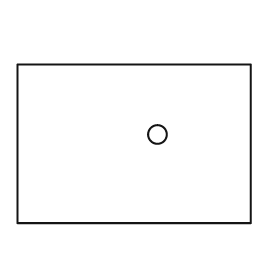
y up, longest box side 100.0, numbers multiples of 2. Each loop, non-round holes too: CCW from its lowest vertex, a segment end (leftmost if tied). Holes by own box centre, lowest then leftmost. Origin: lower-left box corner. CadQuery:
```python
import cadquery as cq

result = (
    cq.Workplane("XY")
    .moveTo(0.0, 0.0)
    .lineTo(100.0, 0.0)
    .lineTo(100.0, 68.0)
    .lineTo(0.0, 68.0)
    .close()
    .moveTo(60.0, 38.0)
    .circle(4.0)
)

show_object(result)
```